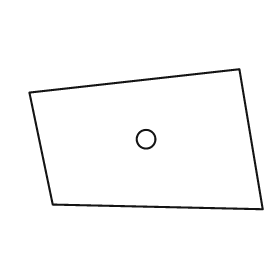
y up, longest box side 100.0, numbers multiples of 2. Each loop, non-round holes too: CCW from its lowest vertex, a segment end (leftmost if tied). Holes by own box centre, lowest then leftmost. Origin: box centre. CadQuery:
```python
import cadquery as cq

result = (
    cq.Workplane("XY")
    .moveTo(50.0, -30.0)
    .lineTo(40.0, 30.0)
    .lineTo(-50.0, 20.0)
    .lineTo(-40.0, -28.0)
    .close()
    .moveTo(0.0, 0.0)
    .circle(4.0)
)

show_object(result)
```